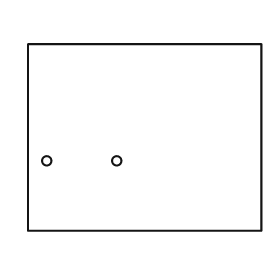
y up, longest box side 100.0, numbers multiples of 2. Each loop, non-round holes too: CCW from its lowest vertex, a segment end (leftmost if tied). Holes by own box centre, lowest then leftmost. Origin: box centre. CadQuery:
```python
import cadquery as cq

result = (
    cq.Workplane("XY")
    .moveTo(-50.0, -40.0)
    .lineTo(50.0, -40.0)
    .lineTo(50.0, 40.0)
    .lineTo(-50.0, 40.0)
    .close()
    .moveTo(-42.0, -10.0)
    .circle(2.0)
    .moveTo(-12.0, -10.0)
    .circle(2.0)
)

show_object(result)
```